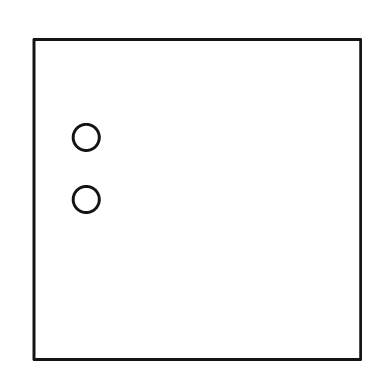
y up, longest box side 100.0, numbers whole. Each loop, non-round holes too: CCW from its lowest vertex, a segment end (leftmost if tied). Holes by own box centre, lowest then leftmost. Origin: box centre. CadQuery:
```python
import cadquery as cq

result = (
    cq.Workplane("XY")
    .moveTo(-50.0, -49.0)
    .lineTo(50.0, -49.0)
    .lineTo(50.0, 49.0)
    .lineTo(-50.0, 49.0)
    .close()
    .moveTo(-34.0, 0.0)
    .circle(4.0)
    .moveTo(-34.0, 19.0)
    .circle(4.0)
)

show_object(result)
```